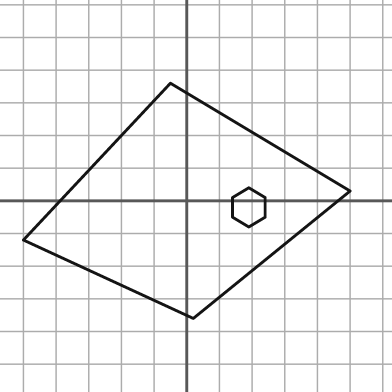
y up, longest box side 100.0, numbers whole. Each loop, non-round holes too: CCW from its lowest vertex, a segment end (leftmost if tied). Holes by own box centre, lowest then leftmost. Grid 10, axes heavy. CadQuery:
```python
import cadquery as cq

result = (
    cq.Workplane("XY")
    .moveTo(2.0, -36.0)
    .lineTo(50.0, 3.0)
    .lineTo(-5.0, 36.0)
    .lineTo(-50.0, -12.0)
    .close()
    .moveTo(19.0, -8.0)
    .lineTo(24.0, -5.0)
    .lineTo(24.0, 1.0)
    .lineTo(19.0, 4.0)
    .lineTo(14.0, 1.0)
    .lineTo(14.0, -5.0)
    .close()
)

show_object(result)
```